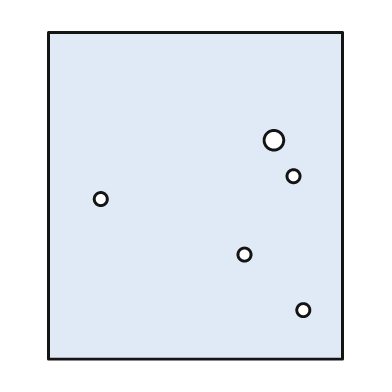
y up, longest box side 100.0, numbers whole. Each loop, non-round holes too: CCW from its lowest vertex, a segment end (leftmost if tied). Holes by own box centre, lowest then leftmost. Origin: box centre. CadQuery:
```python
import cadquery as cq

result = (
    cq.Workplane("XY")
    .moveTo(-45.0, -50.0)
    .lineTo(45.0, -50.0)
    .lineTo(45.0, 50.0)
    .lineTo(-45.0, 50.0)
    .close()
    .moveTo(33.0, -35.0)
    .circle(2.0)
    .moveTo(15.0, -18.0)
    .circle(2.0)
    .moveTo(-29.0, -1.0)
    .circle(2.0)
    .moveTo(30.0, 6.0)
    .circle(2.0)
    .moveTo(24.0, 17.0)
    .circle(3.0)
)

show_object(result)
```